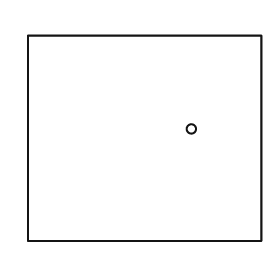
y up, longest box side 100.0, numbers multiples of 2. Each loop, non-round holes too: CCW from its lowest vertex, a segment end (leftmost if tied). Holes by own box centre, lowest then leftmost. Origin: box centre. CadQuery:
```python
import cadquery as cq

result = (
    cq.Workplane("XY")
    .moveTo(-50.0, -44.0)
    .lineTo(50.0, -44.0)
    .lineTo(50.0, 44.0)
    .lineTo(-50.0, 44.0)
    .close()
    .moveTo(20.0, 4.0)
    .circle(2.0)
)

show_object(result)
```